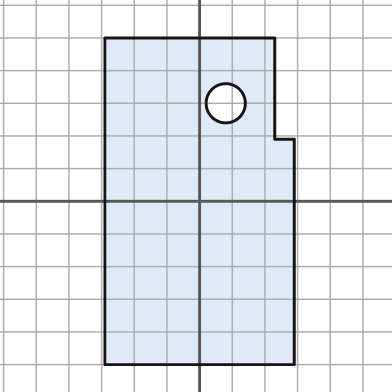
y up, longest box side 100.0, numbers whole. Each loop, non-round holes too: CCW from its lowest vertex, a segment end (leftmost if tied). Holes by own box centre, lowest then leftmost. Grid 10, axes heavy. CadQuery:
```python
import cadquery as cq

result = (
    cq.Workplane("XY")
    .moveTo(-29.0, -50.0)
    .lineTo(29.0, -50.0)
    .lineTo(29.0, 19.0)
    .lineTo(23.0, 19.0)
    .lineTo(23.0, 50.0)
    .lineTo(-29.0, 50.0)
    .close()
    .moveTo(8.0, 30.0)
    .circle(6.0)
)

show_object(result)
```